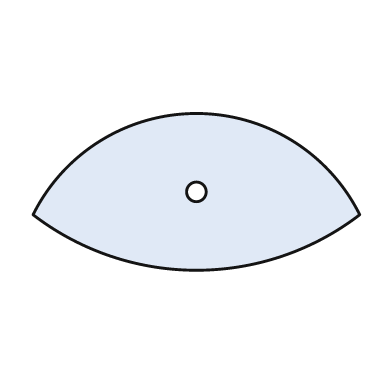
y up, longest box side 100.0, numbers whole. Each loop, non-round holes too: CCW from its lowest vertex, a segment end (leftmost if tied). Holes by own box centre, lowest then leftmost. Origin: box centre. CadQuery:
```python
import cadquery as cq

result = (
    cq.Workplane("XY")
    .moveTo(-50.0, -7.0)
    .threePointArc((0.0, -24.0), (50.0, -7.0))
    .threePointArc((0.0, 24.0), (-50.0, -7.0))
    .close()
    .moveTo(0.0, 0.0)
    .circle(3.0)
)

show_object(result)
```